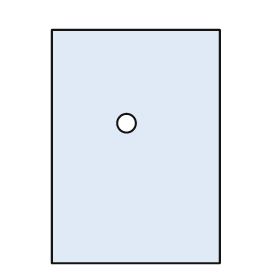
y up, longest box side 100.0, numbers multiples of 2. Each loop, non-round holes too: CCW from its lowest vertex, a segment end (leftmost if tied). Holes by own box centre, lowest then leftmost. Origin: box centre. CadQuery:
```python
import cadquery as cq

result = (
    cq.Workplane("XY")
    .moveTo(-36.0, -50.0)
    .lineTo(36.0, -50.0)
    .lineTo(36.0, 50.0)
    .lineTo(-36.0, 50.0)
    .close()
    .moveTo(-4.0, 10.0)
    .circle(4.0)
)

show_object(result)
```